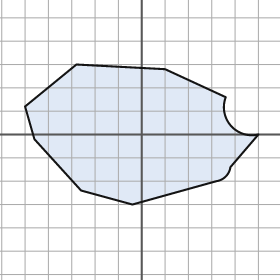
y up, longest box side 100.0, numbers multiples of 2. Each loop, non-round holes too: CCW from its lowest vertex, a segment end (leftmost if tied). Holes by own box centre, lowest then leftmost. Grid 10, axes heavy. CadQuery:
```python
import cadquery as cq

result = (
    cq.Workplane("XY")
    .moveTo(-4.0, -30.0)
    .lineTo(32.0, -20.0)
    .threePointArc((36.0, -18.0), (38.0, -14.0))
    .lineTo(50.0, 0.0)
    .threePointArc((38.0, 4.0), (36.0, 16.0))
    .lineTo(10.0, 28.0)
    .lineTo(-28.0, 30.0)
    .lineTo(-50.0, 12.0)
    .lineTo(-46.0, -2.0)
    .lineTo(-26.0, -24.0)
    .close()
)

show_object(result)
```